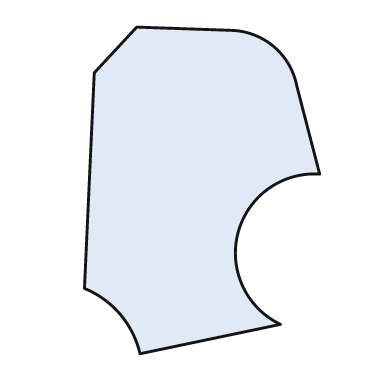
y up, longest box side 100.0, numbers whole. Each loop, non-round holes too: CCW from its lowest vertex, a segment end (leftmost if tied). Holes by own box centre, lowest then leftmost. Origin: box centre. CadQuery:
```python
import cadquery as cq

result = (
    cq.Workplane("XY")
    .moveTo(-19.0, -50.0)
    .lineTo(24.0, -41.0)
    .threePointArc((11.0, -13.0), (36.0, 5.0))
    .lineTo(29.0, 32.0)
    .threePointArc((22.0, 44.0), (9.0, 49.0))
    .lineTo(-20.0, 50.0)
    .lineTo(-33.0, 36.0)
    .lineTo(-36.0, -30.0)
    .threePointArc((-25.0, -38.0), (-19.0, -50.0))
    .close()
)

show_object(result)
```